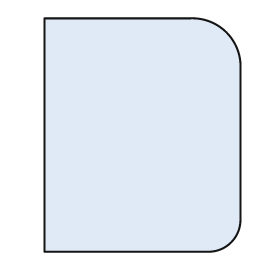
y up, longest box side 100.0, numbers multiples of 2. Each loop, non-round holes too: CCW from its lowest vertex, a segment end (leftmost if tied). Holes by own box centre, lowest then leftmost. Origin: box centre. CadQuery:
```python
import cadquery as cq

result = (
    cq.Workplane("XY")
    .moveTo(-42.0, -50.0)
    .lineTo(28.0, -50.0)
    .threePointArc((38.0, -46.0), (42.0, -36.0))
    .lineTo(42.0, 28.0)
    .threePointArc((36.0, 44.0), (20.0, 50.0))
    .lineTo(-42.0, 50.0)
    .close()
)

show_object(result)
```